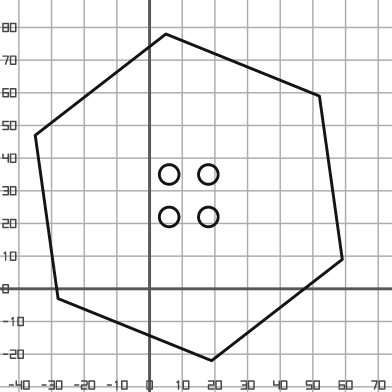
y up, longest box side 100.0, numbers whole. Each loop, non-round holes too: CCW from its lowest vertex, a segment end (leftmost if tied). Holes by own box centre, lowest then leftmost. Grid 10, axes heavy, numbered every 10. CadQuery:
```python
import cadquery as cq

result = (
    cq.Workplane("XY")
    .moveTo(19.0, -22.0)
    .lineTo(59.0, 9.0)
    .lineTo(52.0, 59.0)
    .lineTo(5.0, 78.0)
    .lineTo(-35.0, 47.0)
    .lineTo(-28.0, -3.0)
    .close()
    .moveTo(6.0, 22.0)
    .circle(3.0)
    .moveTo(18.0, 22.0)
    .circle(3.0)
    .moveTo(6.0, 35.0)
    .circle(3.0)
    .moveTo(18.0, 35.0)
    .circle(3.0)
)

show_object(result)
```